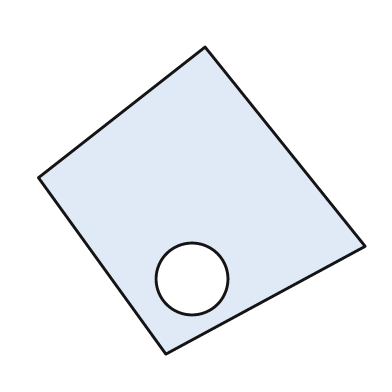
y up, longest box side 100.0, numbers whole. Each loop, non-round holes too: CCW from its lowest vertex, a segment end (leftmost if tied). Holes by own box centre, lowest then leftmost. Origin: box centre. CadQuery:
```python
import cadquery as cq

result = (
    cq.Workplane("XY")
    .moveTo(-11.0, -47.0)
    .lineTo(50.0, -14.0)
    .lineTo(1.0, 47.0)
    .lineTo(-50.0, 7.0)
    .close()
    .moveTo(-3.0, -24.0)
    .circle(11.0)
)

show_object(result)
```